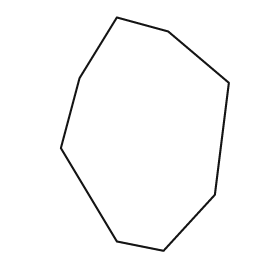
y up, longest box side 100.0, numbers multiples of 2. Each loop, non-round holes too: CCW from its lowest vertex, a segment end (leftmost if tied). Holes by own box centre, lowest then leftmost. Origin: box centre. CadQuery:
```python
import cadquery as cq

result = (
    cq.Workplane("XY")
    .moveTo(8.0, -50.0)
    .lineTo(30.0, -26.0)
    .lineTo(36.0, 22.0)
    .lineTo(10.0, 44.0)
    .lineTo(-12.0, 50.0)
    .lineTo(-28.0, 24.0)
    .lineTo(-36.0, -6.0)
    .lineTo(-12.0, -46.0)
    .close()
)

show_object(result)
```